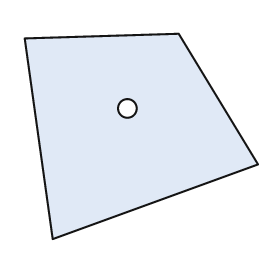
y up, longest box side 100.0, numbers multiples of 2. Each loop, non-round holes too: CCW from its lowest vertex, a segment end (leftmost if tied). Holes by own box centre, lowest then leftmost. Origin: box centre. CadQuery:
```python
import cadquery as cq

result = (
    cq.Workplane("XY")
    .moveTo(-38.0, -44.0)
    .lineTo(50.0, -12.0)
    .lineTo(16.0, 44.0)
    .lineTo(-50.0, 42.0)
    .close()
    .moveTo(-6.0, 12.0)
    .circle(4.0)
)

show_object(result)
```